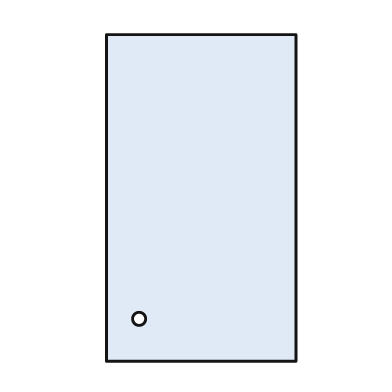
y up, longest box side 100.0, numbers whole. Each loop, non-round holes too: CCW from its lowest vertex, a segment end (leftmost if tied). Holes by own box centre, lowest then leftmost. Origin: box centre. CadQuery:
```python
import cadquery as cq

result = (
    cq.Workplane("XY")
    .moveTo(-29.0, -50.0)
    .lineTo(29.0, -50.0)
    .lineTo(29.0, 50.0)
    .lineTo(-29.0, 50.0)
    .close()
    .moveTo(-19.0, -37.0)
    .circle(2.0)
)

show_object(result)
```